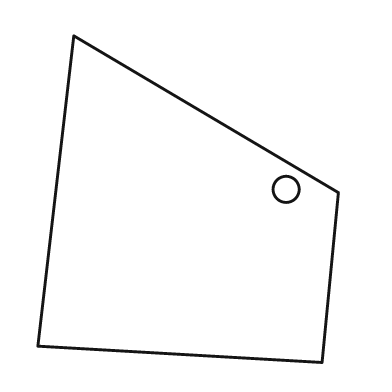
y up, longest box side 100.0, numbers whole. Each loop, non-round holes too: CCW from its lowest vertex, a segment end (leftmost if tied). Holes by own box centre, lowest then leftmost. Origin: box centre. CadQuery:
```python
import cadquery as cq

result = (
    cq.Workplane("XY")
    .moveTo(41.0, -50.0)
    .lineTo(46.0, 2.0)
    .lineTo(-35.0, 50.0)
    .lineTo(-46.0, -45.0)
    .close()
    .moveTo(30.0, 3.0)
    .circle(4.0)
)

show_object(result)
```